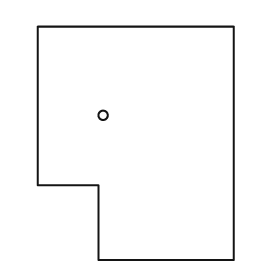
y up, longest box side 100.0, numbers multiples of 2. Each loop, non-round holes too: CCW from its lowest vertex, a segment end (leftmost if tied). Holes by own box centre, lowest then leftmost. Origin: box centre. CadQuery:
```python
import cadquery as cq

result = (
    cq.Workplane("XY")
    .moveTo(-16.0, -50.0)
    .lineTo(42.0, -50.0)
    .lineTo(42.0, 50.0)
    .lineTo(-42.0, 50.0)
    .lineTo(-42.0, -18.0)
    .lineTo(-16.0, -18.0)
    .close()
    .moveTo(-14.0, 12.0)
    .circle(2.0)
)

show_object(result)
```